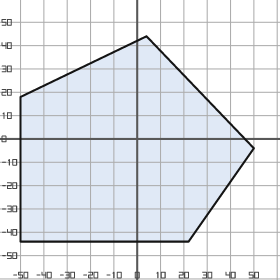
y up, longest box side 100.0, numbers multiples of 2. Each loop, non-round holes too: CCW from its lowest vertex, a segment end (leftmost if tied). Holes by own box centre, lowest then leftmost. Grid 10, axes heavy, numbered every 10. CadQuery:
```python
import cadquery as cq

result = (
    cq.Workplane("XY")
    .moveTo(-50.0, -44.0)
    .lineTo(22.0, -44.0)
    .lineTo(50.0, -4.0)
    .lineTo(4.0, 44.0)
    .lineTo(-50.0, 18.0)
    .close()
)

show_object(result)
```